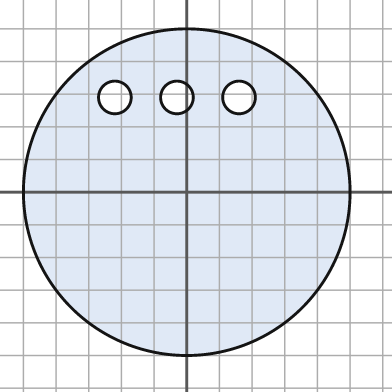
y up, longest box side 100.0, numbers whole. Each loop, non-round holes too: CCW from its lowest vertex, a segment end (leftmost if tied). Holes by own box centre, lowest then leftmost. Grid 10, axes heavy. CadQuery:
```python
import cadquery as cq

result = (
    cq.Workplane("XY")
    .moveTo(0.0, 0.0)
    .circle(50.0)
    .moveTo(-22.0, 29.0)
    .circle(5.0)
    .moveTo(-3.0, 29.0)
    .circle(5.0)
    .moveTo(16.0, 29.0)
    .circle(5.0)
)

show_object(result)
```